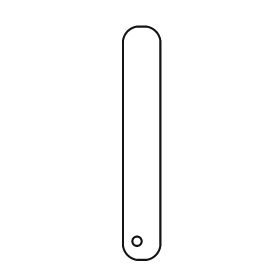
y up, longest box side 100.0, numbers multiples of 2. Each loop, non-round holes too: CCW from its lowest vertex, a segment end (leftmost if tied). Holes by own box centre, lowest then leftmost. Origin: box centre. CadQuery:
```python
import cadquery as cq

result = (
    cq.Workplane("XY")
    .moveTo(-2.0, -50.0)
    .lineTo(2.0, -50.0)
    .threePointArc((6.0, -48.0), (8.0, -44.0))
    .lineTo(8.0, 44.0)
    .threePointArc((6.0, 48.0), (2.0, 50.0))
    .lineTo(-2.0, 50.0)
    .threePointArc((-6.0, 48.0), (-8.0, 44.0))
    .lineTo(-8.0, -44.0)
    .threePointArc((-6.0, -48.0), (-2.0, -50.0))
    .close()
    .moveTo(-2.0, -42.0)
    .circle(2.0)
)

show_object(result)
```